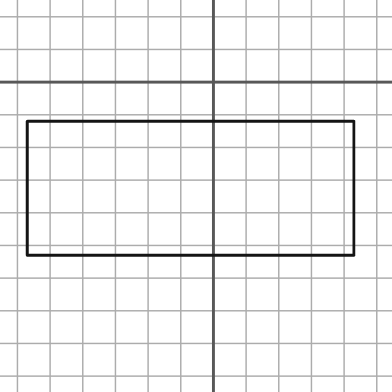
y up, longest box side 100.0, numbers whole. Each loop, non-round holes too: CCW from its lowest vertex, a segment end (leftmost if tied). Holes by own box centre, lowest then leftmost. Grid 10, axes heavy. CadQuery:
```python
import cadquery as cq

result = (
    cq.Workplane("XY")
    .moveTo(-57.0, -53.0)
    .lineTo(43.0, -53.0)
    .lineTo(43.0, -12.0)
    .lineTo(-57.0, -12.0)
    .close()
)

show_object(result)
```